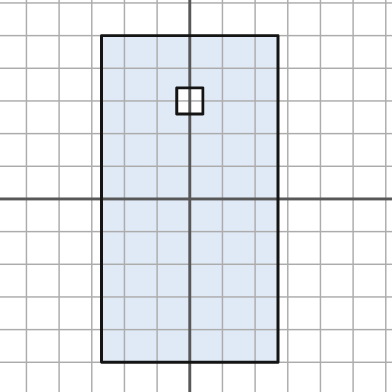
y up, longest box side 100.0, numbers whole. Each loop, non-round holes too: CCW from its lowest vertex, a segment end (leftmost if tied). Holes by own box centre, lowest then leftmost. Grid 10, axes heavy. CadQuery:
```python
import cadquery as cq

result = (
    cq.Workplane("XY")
    .moveTo(-27.0, -50.0)
    .lineTo(27.0, -50.0)
    .lineTo(27.0, 50.0)
    .lineTo(-27.0, 50.0)
    .close()
    .moveTo(-4.0, 26.0)
    .lineTo(4.0, 26.0)
    .lineTo(4.0, 34.0)
    .lineTo(-4.0, 34.0)
    .close()
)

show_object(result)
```